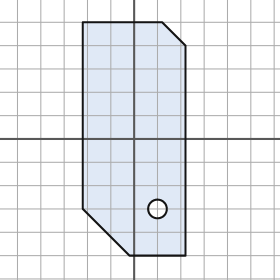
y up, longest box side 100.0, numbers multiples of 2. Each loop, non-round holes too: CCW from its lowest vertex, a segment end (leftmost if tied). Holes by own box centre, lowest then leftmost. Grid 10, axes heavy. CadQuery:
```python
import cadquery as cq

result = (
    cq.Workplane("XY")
    .moveTo(-2.0, -50.0)
    .lineTo(22.0, -50.0)
    .lineTo(22.0, 40.0)
    .lineTo(12.0, 50.0)
    .lineTo(-22.0, 50.0)
    .lineTo(-22.0, -30.0)
    .close()
    .moveTo(10.0, -30.0)
    .circle(4.0)
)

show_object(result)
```